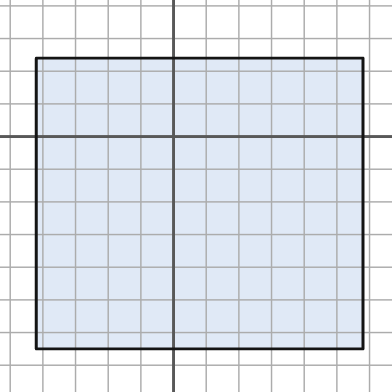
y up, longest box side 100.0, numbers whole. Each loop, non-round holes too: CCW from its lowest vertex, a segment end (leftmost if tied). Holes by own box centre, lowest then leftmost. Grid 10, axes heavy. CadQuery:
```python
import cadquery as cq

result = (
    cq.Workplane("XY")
    .moveTo(-42.0, -65.0)
    .lineTo(58.0, -65.0)
    .lineTo(58.0, 24.0)
    .lineTo(-42.0, 24.0)
    .close()
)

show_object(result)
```